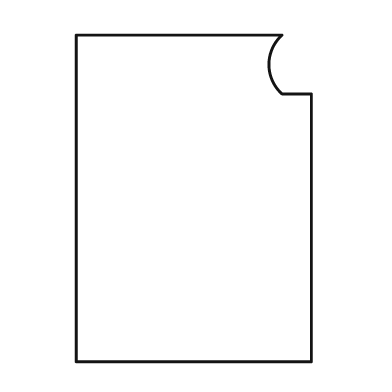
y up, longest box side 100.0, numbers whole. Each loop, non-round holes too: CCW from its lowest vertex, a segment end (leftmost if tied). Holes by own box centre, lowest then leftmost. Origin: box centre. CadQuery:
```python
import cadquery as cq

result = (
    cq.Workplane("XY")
    .moveTo(-36.0, -50.0)
    .lineTo(36.0, -50.0)
    .lineTo(36.0, 32.0)
    .lineTo(27.0, 32.0)
    .threePointArc((23.0, 41.0), (27.0, 50.0))
    .lineTo(-36.0, 50.0)
    .close()
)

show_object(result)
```